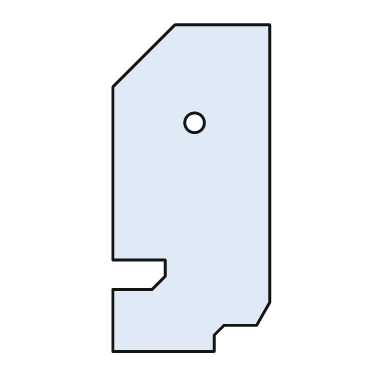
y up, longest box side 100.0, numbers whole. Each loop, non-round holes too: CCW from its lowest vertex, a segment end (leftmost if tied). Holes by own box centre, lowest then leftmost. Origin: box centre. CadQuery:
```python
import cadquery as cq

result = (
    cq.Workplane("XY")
    .moveTo(-24.0, -50.0)
    .lineTo(7.0, -50.0)
    .lineTo(7.0, -45.0)
    .lineTo(10.0, -42.0)
    .lineTo(20.0, -42.0)
    .lineTo(24.0, -35.0)
    .lineTo(24.0, 50.0)
    .lineTo(-5.0, 50.0)
    .lineTo(-24.0, 31.0)
    .lineTo(-24.0, -22.0)
    .lineTo(-8.0, -22.0)
    .lineTo(-8.0, -27.0)
    .lineTo(-12.0, -31.0)
    .lineTo(-24.0, -31.0)
    .close()
    .moveTo(1.0, 20.0)
    .circle(3.0)
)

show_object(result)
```